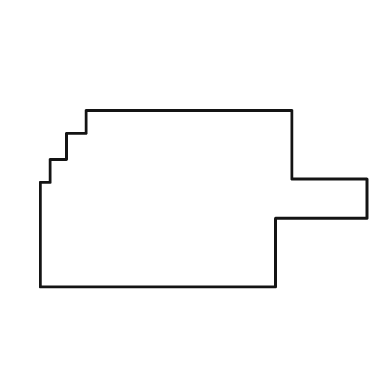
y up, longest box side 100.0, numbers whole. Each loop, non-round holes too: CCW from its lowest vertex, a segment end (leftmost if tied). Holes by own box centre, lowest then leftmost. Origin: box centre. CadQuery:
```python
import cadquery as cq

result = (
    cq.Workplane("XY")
    .moveTo(-50.0, -27.0)
    .lineTo(22.0, -27.0)
    .lineTo(22.0, -6.0)
    .lineTo(50.0, -6.0)
    .lineTo(50.0, 6.0)
    .lineTo(27.0, 6.0)
    .lineTo(27.0, 27.0)
    .lineTo(-36.0, 27.0)
    .lineTo(-36.0, 20.0)
    .lineTo(-42.0, 20.0)
    .lineTo(-42.0, 12.0)
    .lineTo(-47.0, 12.0)
    .lineTo(-47.0, 5.0)
    .lineTo(-50.0, 5.0)
    .close()
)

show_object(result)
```